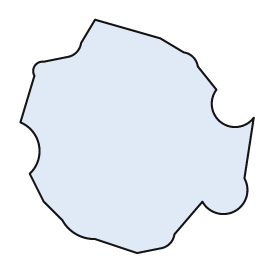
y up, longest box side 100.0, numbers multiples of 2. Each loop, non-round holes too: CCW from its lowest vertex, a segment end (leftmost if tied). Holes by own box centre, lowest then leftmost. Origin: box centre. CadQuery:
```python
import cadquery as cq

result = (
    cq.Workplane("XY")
    .moveTo(0.0, -50.0)
    .lineTo(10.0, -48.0)
    .threePointArc((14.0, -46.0), (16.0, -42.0))
    .lineTo(28.0, -28.0)
    .threePointArc((42.0, -32.0), (46.0, -18.0))
    .lineTo(50.0, 8.0)
    .threePointArc((36.0, 6.0), (34.0, 20.0))
    .lineTo(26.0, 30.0)
    .threePointArc((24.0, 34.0), (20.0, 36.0))
    .lineTo(10.0, 42.0)
    .lineTo(-18.0, 50.0)
    .lineTo(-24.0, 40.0)
    .threePointArc((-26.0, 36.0), (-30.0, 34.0))
    .lineTo(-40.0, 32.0)
    .threePointArc((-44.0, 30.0), (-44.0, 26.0))
    .lineTo(-50.0, 6.0)
    .threePointArc((-42.0, -4.0), (-46.0, -16.0))
    .lineTo(-40.0, -28.0)
    .lineTo(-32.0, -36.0)
    .threePointArc((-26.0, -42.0), (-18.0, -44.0))
    .close()
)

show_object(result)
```